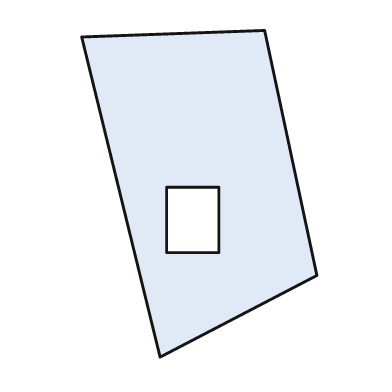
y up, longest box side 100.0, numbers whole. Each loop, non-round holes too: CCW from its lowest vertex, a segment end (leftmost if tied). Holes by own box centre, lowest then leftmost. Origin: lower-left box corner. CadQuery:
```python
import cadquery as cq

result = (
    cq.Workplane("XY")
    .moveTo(24.0, 0.0)
    .lineTo(72.0, 25.0)
    .lineTo(56.0, 100.0)
    .lineTo(0.0, 98.0)
    .close()
    .moveTo(26.0, 32.0)
    .lineTo(42.0, 32.0)
    .lineTo(42.0, 52.0)
    .lineTo(26.0, 52.0)
    .close()
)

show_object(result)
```